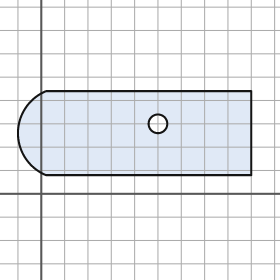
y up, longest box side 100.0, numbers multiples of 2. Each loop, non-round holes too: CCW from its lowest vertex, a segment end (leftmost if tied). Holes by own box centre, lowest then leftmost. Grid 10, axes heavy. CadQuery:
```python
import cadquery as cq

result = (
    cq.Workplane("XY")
    .moveTo(2.0, 8.0)
    .lineTo(90.0, 8.0)
    .lineTo(90.0, 44.0)
    .lineTo(2.0, 44.0)
    .threePointArc((-10.0, 26.0), (2.0, 8.0))
    .close()
    .moveTo(50.0, 30.0)
    .circle(4.0)
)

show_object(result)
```